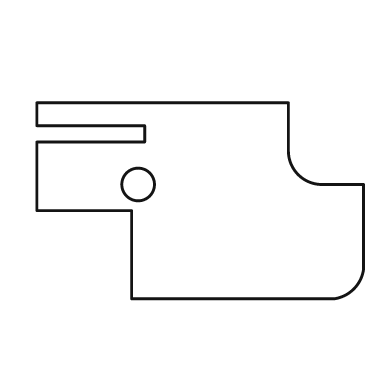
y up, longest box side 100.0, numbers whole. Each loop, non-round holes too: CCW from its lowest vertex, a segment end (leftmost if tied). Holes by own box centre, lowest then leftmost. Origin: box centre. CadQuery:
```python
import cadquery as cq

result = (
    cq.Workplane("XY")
    .moveTo(-21.0, -30.0)
    .lineTo(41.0, -30.0)
    .threePointArc((47.0, -27.0), (50.0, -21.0))
    .lineTo(50.0, 5.0)
    .lineTo(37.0, 5.0)
    .threePointArc((30.0, 8.0), (27.0, 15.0))
    .lineTo(27.0, 30.0)
    .lineTo(-50.0, 30.0)
    .lineTo(-50.0, 23.0)
    .lineTo(-17.0, 23.0)
    .lineTo(-17.0, 18.0)
    .lineTo(-50.0, 18.0)
    .lineTo(-50.0, -3.0)
    .lineTo(-21.0, -3.0)
    .close()
    .moveTo(-19.0, 5.0)
    .circle(5.0)
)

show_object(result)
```